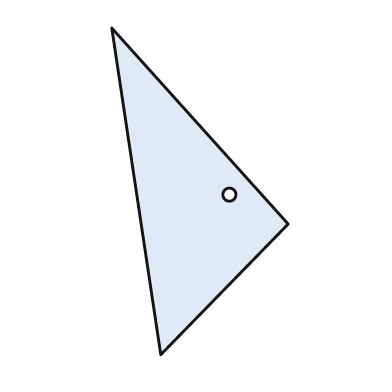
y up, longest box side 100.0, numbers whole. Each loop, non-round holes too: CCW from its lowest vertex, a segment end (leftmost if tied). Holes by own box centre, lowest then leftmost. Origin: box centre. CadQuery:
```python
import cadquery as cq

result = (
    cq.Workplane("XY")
    .moveTo(-12.0, -50.0)
    .lineTo(27.0, -10.0)
    .lineTo(-27.0, 50.0)
    .close()
    .moveTo(9.0, -1.0)
    .circle(2.0)
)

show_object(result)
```